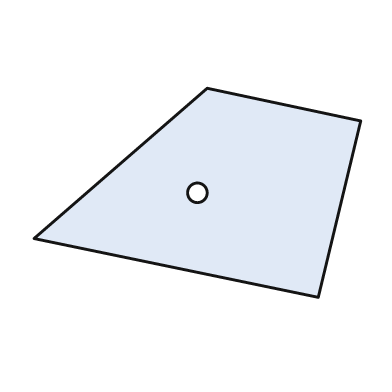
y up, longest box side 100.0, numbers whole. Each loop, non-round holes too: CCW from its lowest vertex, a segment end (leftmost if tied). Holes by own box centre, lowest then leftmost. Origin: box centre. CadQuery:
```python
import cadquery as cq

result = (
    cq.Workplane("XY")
    .moveTo(37.0, -32.0)
    .lineTo(50.0, 22.0)
    .lineTo(3.0, 32.0)
    .lineTo(-50.0, -14.0)
    .close()
    .moveTo(0.0, 0.0)
    .circle(3.0)
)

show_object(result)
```